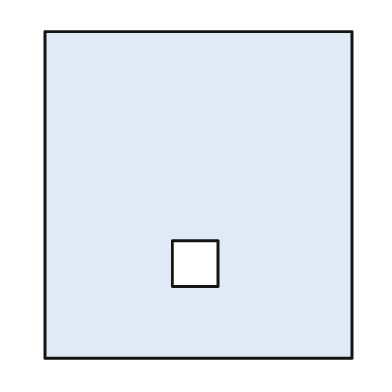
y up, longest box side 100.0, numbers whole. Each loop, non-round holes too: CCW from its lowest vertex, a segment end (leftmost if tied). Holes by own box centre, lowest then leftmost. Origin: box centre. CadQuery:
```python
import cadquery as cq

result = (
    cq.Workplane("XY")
    .moveTo(-47.0, -50.0)
    .lineTo(47.0, -50.0)
    .lineTo(47.0, 50.0)
    .lineTo(-47.0, 50.0)
    .close()
    .moveTo(-8.0, -28.0)
    .lineTo(6.0, -28.0)
    .lineTo(6.0, -14.0)
    .lineTo(-8.0, -14.0)
    .close()
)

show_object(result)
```